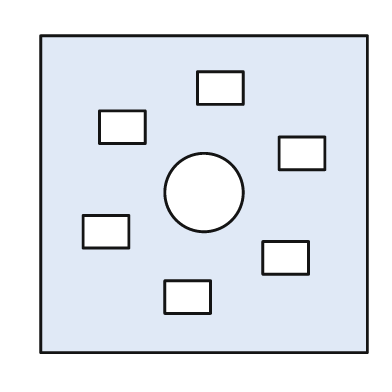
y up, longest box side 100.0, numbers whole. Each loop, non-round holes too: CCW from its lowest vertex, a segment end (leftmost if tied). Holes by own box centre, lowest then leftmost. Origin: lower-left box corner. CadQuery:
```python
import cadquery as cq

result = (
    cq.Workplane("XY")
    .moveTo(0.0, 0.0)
    .lineTo(100.0, 0.0)
    .lineTo(100.0, 97.0)
    .lineTo(0.0, 97.0)
    .close()
    .moveTo(38.0, 12.0)
    .lineTo(52.0, 12.0)
    .lineTo(52.0, 22.0)
    .lineTo(38.0, 22.0)
    .close()
    .moveTo(68.0, 24.0)
    .lineTo(82.0, 24.0)
    .lineTo(82.0, 34.0)
    .lineTo(68.0, 34.0)
    .close()
    .moveTo(13.0, 32.0)
    .lineTo(27.0, 32.0)
    .lineTo(27.0, 42.0)
    .lineTo(13.0, 42.0)
    .close()
    .moveTo(50.0, 49.0)
    .circle(12.0)
    .moveTo(73.0, 56.0)
    .lineTo(87.0, 56.0)
    .lineTo(87.0, 66.0)
    .lineTo(73.0, 66.0)
    .close()
    .moveTo(18.0, 64.0)
    .lineTo(32.0, 64.0)
    .lineTo(32.0, 74.0)
    .lineTo(18.0, 74.0)
    .close()
    .moveTo(48.0, 76.0)
    .lineTo(62.0, 76.0)
    .lineTo(62.0, 86.0)
    .lineTo(48.0, 86.0)
    .close()
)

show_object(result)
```